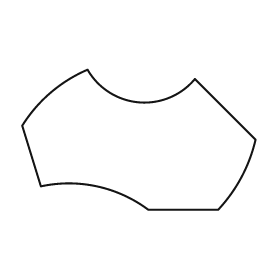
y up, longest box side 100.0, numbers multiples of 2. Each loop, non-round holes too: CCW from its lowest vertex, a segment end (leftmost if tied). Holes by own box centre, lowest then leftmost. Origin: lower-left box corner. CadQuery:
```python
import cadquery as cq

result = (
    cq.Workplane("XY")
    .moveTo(54.0, 0.0)
    .lineTo(84.0, 0.0)
    .threePointArc((94.0, 14.0), (100.0, 30.0))
    .lineTo(74.0, 56.0)
    .threePointArc((50.0, 46.0), (28.0, 60.0))
    .threePointArc((12.0, 50.0), (0.0, 36.0))
    .lineTo(8.0, 10.0)
    .threePointArc((32.0, 10.0), (54.0, 0.0))
    .close()
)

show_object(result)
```